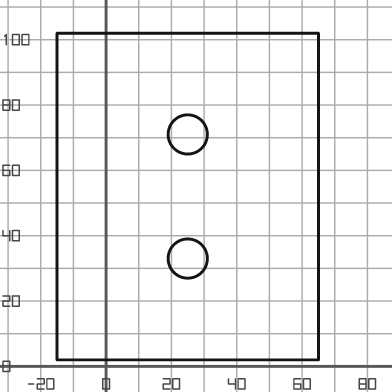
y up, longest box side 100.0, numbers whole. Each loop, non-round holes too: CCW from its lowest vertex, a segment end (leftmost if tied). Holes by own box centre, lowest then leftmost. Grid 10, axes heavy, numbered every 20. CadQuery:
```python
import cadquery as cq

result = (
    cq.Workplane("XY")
    .moveTo(-15.0, 2.0)
    .lineTo(65.0, 2.0)
    .lineTo(65.0, 102.0)
    .lineTo(-15.0, 102.0)
    .close()
    .moveTo(25.0, 33.0)
    .circle(6.0)
    .moveTo(25.0, 71.0)
    .circle(6.0)
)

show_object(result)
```